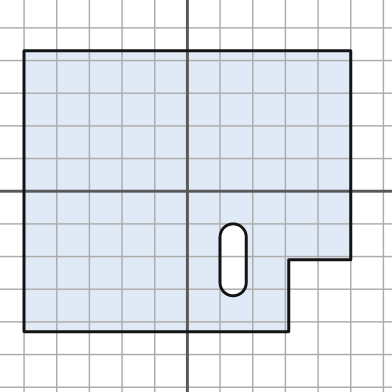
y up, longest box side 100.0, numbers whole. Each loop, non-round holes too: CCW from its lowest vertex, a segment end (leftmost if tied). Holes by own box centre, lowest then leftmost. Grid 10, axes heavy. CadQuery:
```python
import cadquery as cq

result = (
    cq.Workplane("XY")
    .moveTo(-50.0, -43.0)
    .lineTo(31.0, -43.0)
    .lineTo(31.0, -21.0)
    .lineTo(50.0, -21.0)
    .lineTo(50.0, 43.0)
    .lineTo(-50.0, 43.0)
    .close()
    .moveTo(10.0, -28.0)
    .threePointArc((14.0, -32.0), (18.0, -28.0))
    .lineTo(18.0, -14.0)
    .threePointArc((14.0, -10.0), (10.0, -14.0))
    .close()
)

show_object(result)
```